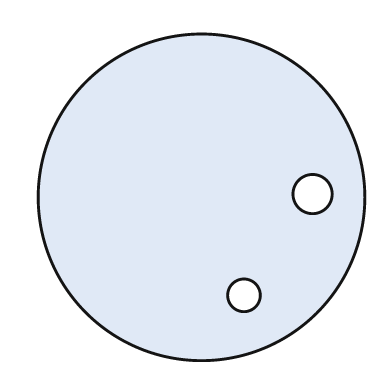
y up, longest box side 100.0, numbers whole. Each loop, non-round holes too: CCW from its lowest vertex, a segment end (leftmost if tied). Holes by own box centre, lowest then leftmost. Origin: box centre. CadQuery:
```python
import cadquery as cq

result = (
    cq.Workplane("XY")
    .moveTo(0.0, 0.0)
    .circle(50.0)
    .moveTo(13.0, -30.0)
    .circle(5.0)
    .moveTo(34.0, 1.0)
    .circle(6.0)
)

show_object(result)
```